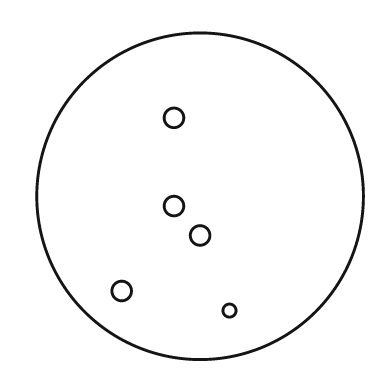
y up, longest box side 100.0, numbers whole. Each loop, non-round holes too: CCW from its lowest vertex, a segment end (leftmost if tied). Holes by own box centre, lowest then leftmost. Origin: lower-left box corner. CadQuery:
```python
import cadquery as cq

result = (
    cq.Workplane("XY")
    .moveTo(50.0, 50.0)
    .circle(50.0)
    .moveTo(59.0, 15.0)
    .circle(2.0)
    .moveTo(26.0, 21.0)
    .circle(3.0)
    .moveTo(50.0, 38.0)
    .circle(3.0)
    .moveTo(42.0, 47.0)
    .circle(3.0)
    .moveTo(42.0, 74.0)
    .circle(3.0)
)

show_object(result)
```